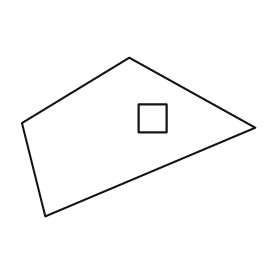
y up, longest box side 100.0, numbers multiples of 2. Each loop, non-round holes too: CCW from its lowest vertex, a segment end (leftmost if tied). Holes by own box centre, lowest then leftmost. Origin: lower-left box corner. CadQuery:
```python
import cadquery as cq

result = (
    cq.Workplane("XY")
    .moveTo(10.0, 0.0)
    .lineTo(100.0, 38.0)
    .lineTo(46.0, 68.0)
    .lineTo(0.0, 40.0)
    .close()
    .moveTo(50.0, 36.0)
    .lineTo(62.0, 36.0)
    .lineTo(62.0, 48.0)
    .lineTo(50.0, 48.0)
    .close()
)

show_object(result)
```